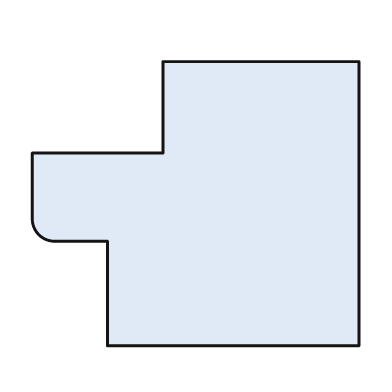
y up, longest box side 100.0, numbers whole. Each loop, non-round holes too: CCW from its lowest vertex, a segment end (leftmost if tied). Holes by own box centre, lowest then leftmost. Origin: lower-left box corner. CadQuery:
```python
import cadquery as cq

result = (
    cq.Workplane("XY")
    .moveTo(23.0, 0.0)
    .lineTo(100.0, 0.0)
    .lineTo(100.0, 87.0)
    .lineTo(40.0, 87.0)
    .lineTo(40.0, 59.0)
    .lineTo(0.0, 59.0)
    .lineTo(0.0, 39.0)
    .threePointArc((2.0, 34.0), (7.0, 32.0))
    .lineTo(23.0, 32.0)
    .close()
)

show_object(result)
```